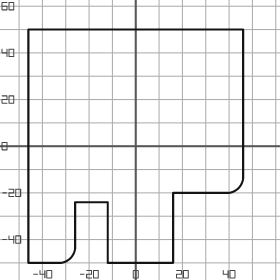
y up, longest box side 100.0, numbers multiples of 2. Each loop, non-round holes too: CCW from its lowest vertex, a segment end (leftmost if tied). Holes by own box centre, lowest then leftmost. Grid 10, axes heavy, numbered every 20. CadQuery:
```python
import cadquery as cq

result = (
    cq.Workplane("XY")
    .moveTo(-46.0, -50.0)
    .lineTo(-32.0, -50.0)
    .threePointArc((-28.0, -48.0), (-26.0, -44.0))
    .lineTo(-26.0, -24.0)
    .lineTo(-12.0, -24.0)
    .lineTo(-12.0, -50.0)
    .lineTo(16.0, -50.0)
    .lineTo(16.0, -20.0)
    .lineTo(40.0, -20.0)
    .threePointArc((44.0, -18.0), (46.0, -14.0))
    .lineTo(46.0, 50.0)
    .lineTo(-46.0, 50.0)
    .close()
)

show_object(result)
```